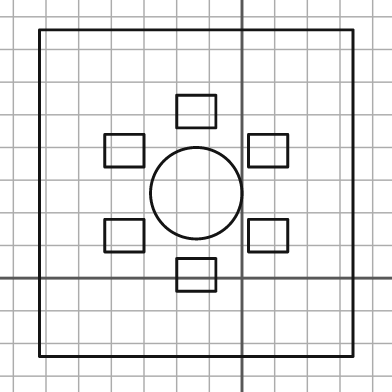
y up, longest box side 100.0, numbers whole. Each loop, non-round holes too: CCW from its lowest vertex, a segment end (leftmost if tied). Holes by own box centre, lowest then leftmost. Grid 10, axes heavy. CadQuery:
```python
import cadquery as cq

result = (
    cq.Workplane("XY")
    .moveTo(-62.0, -24.0)
    .lineTo(34.0, -24.0)
    .lineTo(34.0, 76.0)
    .lineTo(-62.0, 76.0)
    .close()
    .moveTo(-20.0, -4.0)
    .lineTo(-8.0, -4.0)
    .lineTo(-8.0, 6.0)
    .lineTo(-20.0, 6.0)
    .close()
    .moveTo(-42.0, 8.0)
    .lineTo(-30.0, 8.0)
    .lineTo(-30.0, 18.0)
    .lineTo(-42.0, 18.0)
    .close()
    .moveTo(2.0, 8.0)
    .lineTo(14.0, 8.0)
    .lineTo(14.0, 18.0)
    .lineTo(2.0, 18.0)
    .close()
    .moveTo(-14.0, 26.0)
    .circle(14.0)
    .moveTo(-42.0, 34.0)
    .lineTo(-30.0, 34.0)
    .lineTo(-30.0, 44.0)
    .lineTo(-42.0, 44.0)
    .close()
    .moveTo(2.0, 34.0)
    .lineTo(14.0, 34.0)
    .lineTo(14.0, 44.0)
    .lineTo(2.0, 44.0)
    .close()
    .moveTo(-20.0, 46.0)
    .lineTo(-8.0, 46.0)
    .lineTo(-8.0, 56.0)
    .lineTo(-20.0, 56.0)
    .close()
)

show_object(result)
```